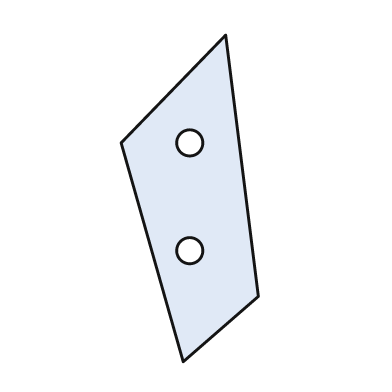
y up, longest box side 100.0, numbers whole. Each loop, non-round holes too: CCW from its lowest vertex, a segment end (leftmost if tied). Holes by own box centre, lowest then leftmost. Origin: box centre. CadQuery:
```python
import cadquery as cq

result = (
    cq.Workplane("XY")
    .moveTo(-2.0, -50.0)
    .lineTo(21.0, -30.0)
    .lineTo(11.0, 50.0)
    .lineTo(-21.0, 17.0)
    .close()
    .moveTo(0.0, -16.0)
    .circle(4.0)
    .moveTo(0.0, 17.0)
    .circle(4.0)
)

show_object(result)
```